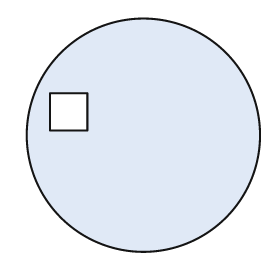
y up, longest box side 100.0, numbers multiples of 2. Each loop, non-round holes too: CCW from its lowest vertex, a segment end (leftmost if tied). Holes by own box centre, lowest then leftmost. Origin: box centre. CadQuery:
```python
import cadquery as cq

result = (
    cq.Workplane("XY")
    .moveTo(0.0, 0.0)
    .circle(50.0)
    .moveTo(-40.0, 2.0)
    .lineTo(-24.0, 2.0)
    .lineTo(-24.0, 18.0)
    .lineTo(-40.0, 18.0)
    .close()
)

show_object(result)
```